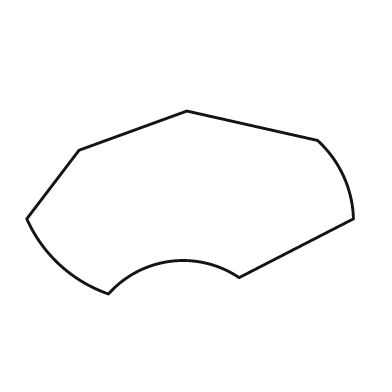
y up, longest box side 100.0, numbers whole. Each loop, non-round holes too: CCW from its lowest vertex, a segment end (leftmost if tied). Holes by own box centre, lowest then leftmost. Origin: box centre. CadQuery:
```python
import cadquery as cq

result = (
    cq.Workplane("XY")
    .moveTo(-25.0, -28.0)
    .threePointArc((-6.0, -18.0), (15.0, -23.0))
    .lineTo(50.0, -5.0)
    .threePointArc((47.0, 8.0), (39.0, 19.0))
    .lineTo(-1.0, 28.0)
    .lineTo(-34.0, 16.0)
    .lineTo(-50.0, -5.0)
    .threePointArc((-40.0, -19.0), (-25.0, -28.0))
    .close()
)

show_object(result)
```